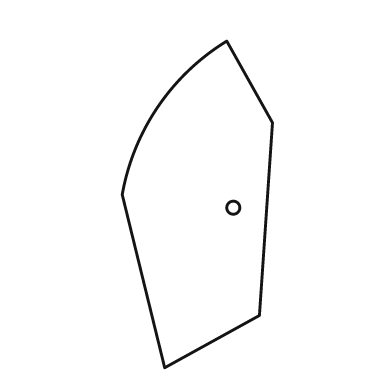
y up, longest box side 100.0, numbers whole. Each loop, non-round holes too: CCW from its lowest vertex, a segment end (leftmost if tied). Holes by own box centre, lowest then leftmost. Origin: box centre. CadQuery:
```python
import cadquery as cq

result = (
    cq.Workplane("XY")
    .moveTo(-10.0, -50.0)
    .lineTo(19.0, -34.0)
    .lineTo(23.0, 25.0)
    .lineTo(9.0, 50.0)
    .threePointArc((-12.0, 30.0), (-23.0, 3.0))
    .close()
    .moveTo(11.0, -1.0)
    .circle(2.0)
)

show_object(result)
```